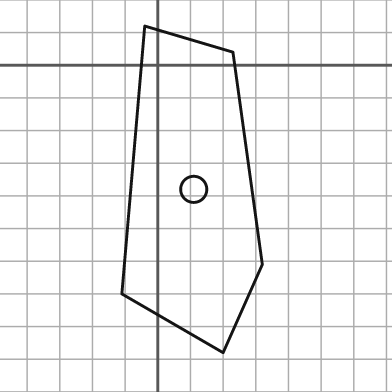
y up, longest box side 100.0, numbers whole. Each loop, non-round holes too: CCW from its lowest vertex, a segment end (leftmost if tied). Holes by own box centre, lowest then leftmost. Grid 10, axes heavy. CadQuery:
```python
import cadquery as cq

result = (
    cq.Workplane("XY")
    .moveTo(20.0, -88.0)
    .lineTo(32.0, -61.0)
    .lineTo(23.0, 4.0)
    .lineTo(-4.0, 12.0)
    .lineTo(-11.0, -70.0)
    .close()
    .moveTo(11.0, -38.0)
    .circle(4.0)
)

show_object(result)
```